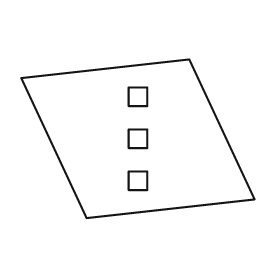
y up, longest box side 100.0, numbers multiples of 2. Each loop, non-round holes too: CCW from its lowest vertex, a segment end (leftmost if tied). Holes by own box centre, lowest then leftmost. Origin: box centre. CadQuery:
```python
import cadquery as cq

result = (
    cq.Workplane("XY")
    .moveTo(-22.0, -34.0)
    .lineTo(50.0, -26.0)
    .lineTo(22.0, 34.0)
    .lineTo(-50.0, 26.0)
    .close()
    .moveTo(-4.0, -22.0)
    .lineTo(4.0, -22.0)
    .lineTo(4.0, -14.0)
    .lineTo(-4.0, -14.0)
    .close()
    .moveTo(-4.0, -4.0)
    .lineTo(4.0, -4.0)
    .lineTo(4.0, 4.0)
    .lineTo(-4.0, 4.0)
    .close()
    .moveTo(-4.0, 14.0)
    .lineTo(4.0, 14.0)
    .lineTo(4.0, 22.0)
    .lineTo(-4.0, 22.0)
    .close()
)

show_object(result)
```